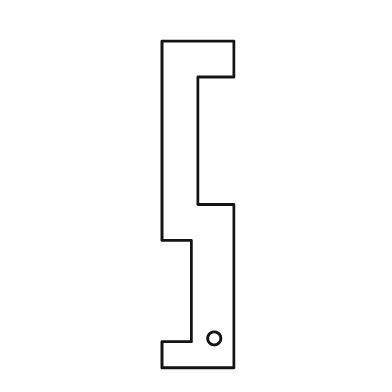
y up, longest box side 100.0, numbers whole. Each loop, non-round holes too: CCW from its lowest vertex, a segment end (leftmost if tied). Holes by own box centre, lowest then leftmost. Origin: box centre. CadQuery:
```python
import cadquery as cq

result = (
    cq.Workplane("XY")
    .moveTo(-11.0, -50.0)
    .lineTo(11.0, -50.0)
    .lineTo(11.0, 0.0)
    .lineTo(0.0, 0.0)
    .lineTo(0.0, 39.0)
    .lineTo(11.0, 39.0)
    .lineTo(11.0, 50.0)
    .lineTo(-11.0, 50.0)
    .lineTo(-11.0, -11.0)
    .lineTo(-2.0, -11.0)
    .lineTo(-2.0, -42.0)
    .lineTo(-11.0, -42.0)
    .close()
    .moveTo(5.0, -41.0)
    .circle(2.0)
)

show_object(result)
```